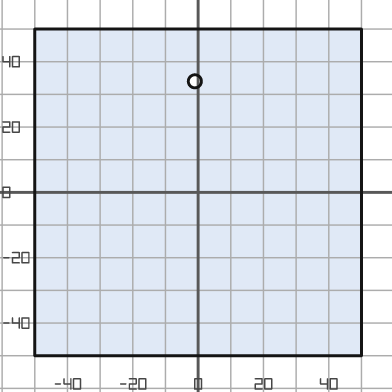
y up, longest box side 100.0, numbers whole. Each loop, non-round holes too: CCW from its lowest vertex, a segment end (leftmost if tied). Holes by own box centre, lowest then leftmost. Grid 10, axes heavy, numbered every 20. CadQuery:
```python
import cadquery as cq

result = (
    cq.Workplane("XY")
    .moveTo(-50.0, -50.0)
    .lineTo(50.0, -50.0)
    .lineTo(50.0, 50.0)
    .lineTo(-50.0, 50.0)
    .close()
    .moveTo(-1.0, 34.0)
    .circle(2.0)
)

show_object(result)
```